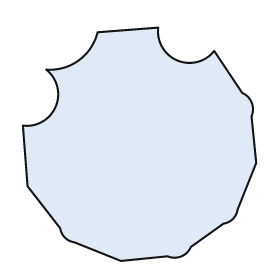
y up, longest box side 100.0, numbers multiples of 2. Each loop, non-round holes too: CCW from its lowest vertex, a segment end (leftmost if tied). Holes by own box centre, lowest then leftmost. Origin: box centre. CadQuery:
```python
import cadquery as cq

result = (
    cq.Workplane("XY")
    .moveTo(-8.0, -50.0)
    .lineTo(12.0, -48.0)
    .threePointArc((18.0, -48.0), (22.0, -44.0))
    .lineTo(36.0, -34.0)
    .threePointArc((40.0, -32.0), (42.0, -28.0))
    .lineTo(50.0, -8.0)
    .lineTo(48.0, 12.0)
    .threePointArc((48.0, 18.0), (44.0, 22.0))
    .lineTo(32.0, 40.0)
    .threePointArc((16.0, 36.0), (8.0, 50.0))
    .lineTo(-18.0, 48.0)
    .threePointArc((-26.0, 36.0), (-40.0, 32.0))
    .threePointArc((-36.0, 16.0), (-50.0, 8.0))
    .lineTo(-48.0, -18.0)
    .lineTo(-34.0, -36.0)
    .threePointArc((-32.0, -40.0), (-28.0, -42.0))
    .close()
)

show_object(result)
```